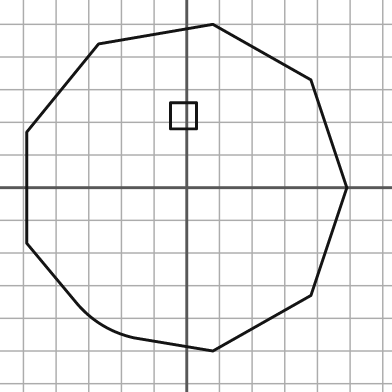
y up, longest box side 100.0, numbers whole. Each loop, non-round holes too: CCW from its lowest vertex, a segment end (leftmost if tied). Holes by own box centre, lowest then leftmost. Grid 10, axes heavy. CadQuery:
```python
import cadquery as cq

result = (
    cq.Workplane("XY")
    .moveTo(8.0, -50.0)
    .lineTo(38.0, -33.0)
    .lineTo(49.0, 0.0)
    .lineTo(38.0, 33.0)
    .lineTo(8.0, 50.0)
    .lineTo(-27.0, 44.0)
    .lineTo(-49.0, 17.0)
    .lineTo(-49.0, -17.0)
    .lineTo(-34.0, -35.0)
    .threePointArc((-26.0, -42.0), (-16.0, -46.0))
    .close()
    .moveTo(-5.0, 18.0)
    .lineTo(3.0, 18.0)
    .lineTo(3.0, 26.0)
    .lineTo(-5.0, 26.0)
    .close()
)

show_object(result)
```